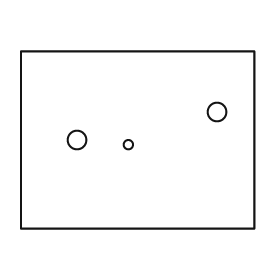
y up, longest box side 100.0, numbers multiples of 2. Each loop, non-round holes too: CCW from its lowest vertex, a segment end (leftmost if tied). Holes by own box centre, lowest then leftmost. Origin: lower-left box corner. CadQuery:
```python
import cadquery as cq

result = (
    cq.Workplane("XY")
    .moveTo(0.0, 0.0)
    .lineTo(100.0, 0.0)
    .lineTo(100.0, 76.0)
    .lineTo(0.0, 76.0)
    .close()
    .moveTo(46.0, 36.0)
    .circle(2.0)
    .moveTo(24.0, 38.0)
    .circle(4.0)
    .moveTo(84.0, 50.0)
    .circle(4.0)
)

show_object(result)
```